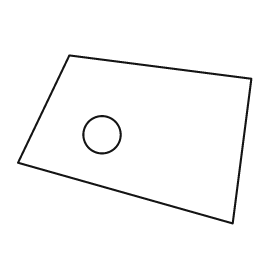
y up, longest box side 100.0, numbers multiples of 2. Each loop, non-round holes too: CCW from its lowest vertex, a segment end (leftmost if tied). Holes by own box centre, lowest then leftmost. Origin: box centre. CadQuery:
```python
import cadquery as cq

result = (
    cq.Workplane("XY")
    .moveTo(42.0, -36.0)
    .lineTo(50.0, 26.0)
    .lineTo(-28.0, 36.0)
    .lineTo(-50.0, -10.0)
    .close()
    .moveTo(-14.0, 2.0)
    .circle(8.0)
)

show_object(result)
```